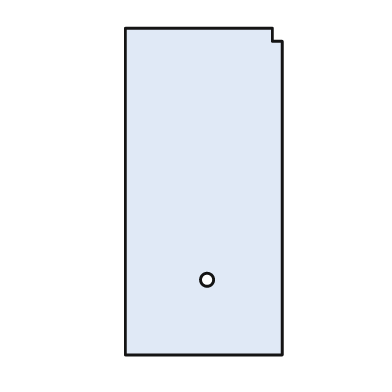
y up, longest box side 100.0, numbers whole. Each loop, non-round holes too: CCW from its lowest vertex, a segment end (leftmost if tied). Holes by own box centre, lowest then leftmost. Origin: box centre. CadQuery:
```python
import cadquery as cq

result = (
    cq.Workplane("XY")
    .moveTo(-24.0, -50.0)
    .lineTo(24.0, -50.0)
    .lineTo(24.0, 46.0)
    .lineTo(21.0, 46.0)
    .lineTo(21.0, 50.0)
    .lineTo(-24.0, 50.0)
    .close()
    .moveTo(1.0, -27.0)
    .circle(2.0)
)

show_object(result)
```